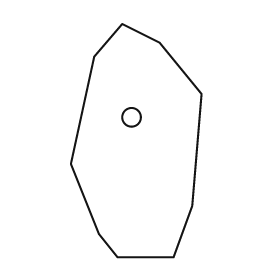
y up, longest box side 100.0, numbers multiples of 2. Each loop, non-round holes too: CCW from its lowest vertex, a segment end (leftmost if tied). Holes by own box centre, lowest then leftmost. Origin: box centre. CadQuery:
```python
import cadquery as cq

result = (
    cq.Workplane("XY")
    .moveTo(-8.0, -50.0)
    .lineTo(16.0, -50.0)
    .lineTo(24.0, -28.0)
    .lineTo(28.0, 20.0)
    .lineTo(10.0, 42.0)
    .lineTo(-6.0, 50.0)
    .lineTo(-18.0, 36.0)
    .lineTo(-28.0, -10.0)
    .lineTo(-16.0, -40.0)
    .close()
    .moveTo(-2.0, 10.0)
    .circle(4.0)
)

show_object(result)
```